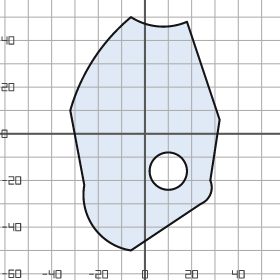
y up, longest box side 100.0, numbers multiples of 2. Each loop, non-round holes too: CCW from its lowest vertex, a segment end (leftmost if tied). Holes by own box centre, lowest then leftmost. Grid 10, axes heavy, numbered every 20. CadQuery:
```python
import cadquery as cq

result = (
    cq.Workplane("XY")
    .moveTo(-6.0, -50.0)
    .lineTo(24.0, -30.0)
    .threePointArc((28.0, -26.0), (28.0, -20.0))
    .lineTo(32.0, 6.0)
    .lineTo(18.0, 48.0)
    .threePointArc((6.0, 46.0), (-6.0, 50.0))
    .threePointArc((-22.0, 32.0), (-32.0, 10.0))
    .lineTo(-26.0, -22.0)
    .threePointArc((-22.0, -40.0), (-6.0, -50.0))
    .close()
    .moveTo(10.0, -16.0)
    .circle(8.0)
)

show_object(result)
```